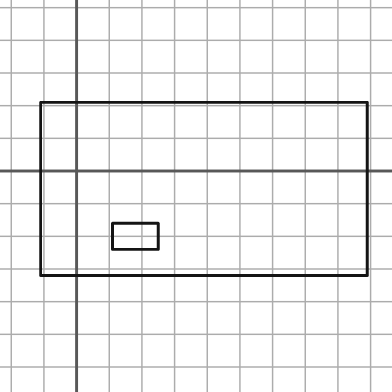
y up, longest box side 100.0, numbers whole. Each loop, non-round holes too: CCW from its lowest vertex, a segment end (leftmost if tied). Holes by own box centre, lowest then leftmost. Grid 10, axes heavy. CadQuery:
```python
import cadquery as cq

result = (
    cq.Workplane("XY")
    .moveTo(-11.0, -32.0)
    .lineTo(89.0, -32.0)
    .lineTo(89.0, 21.0)
    .lineTo(-11.0, 21.0)
    .close()
    .moveTo(11.0, -24.0)
    .lineTo(25.0, -24.0)
    .lineTo(25.0, -16.0)
    .lineTo(11.0, -16.0)
    .close()
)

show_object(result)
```